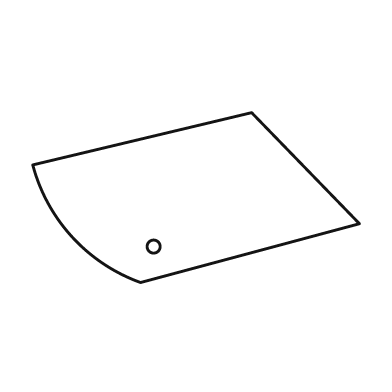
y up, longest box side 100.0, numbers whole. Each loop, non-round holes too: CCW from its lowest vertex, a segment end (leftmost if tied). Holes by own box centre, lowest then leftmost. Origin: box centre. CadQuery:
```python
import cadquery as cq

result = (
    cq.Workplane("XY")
    .moveTo(-17.0, -26.0)
    .lineTo(50.0, -8.0)
    .lineTo(17.0, 26.0)
    .lineTo(-50.0, 10.0)
    .threePointArc((-38.0, -12.0), (-17.0, -26.0))
    .close()
    .moveTo(-13.0, -15.0)
    .circle(2.0)
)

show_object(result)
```